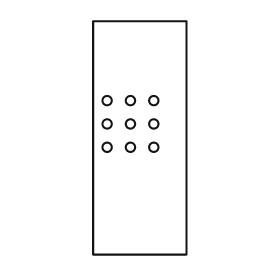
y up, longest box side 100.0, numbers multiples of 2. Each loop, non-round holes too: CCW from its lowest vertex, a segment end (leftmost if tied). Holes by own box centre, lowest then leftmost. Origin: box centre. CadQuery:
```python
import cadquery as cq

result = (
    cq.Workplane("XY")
    .moveTo(-20.0, -50.0)
    .lineTo(20.0, -50.0)
    .lineTo(20.0, 50.0)
    .lineTo(-20.0, 50.0)
    .close()
    .moveTo(-14.0, -4.0)
    .circle(2.0)
    .moveTo(-4.0, -4.0)
    .circle(2.0)
    .moveTo(6.0, -4.0)
    .circle(2.0)
    .moveTo(-14.0, 6.0)
    .circle(2.0)
    .moveTo(-4.0, 6.0)
    .circle(2.0)
    .moveTo(6.0, 6.0)
    .circle(2.0)
    .moveTo(-14.0, 16.0)
    .circle(2.0)
    .moveTo(-4.0, 16.0)
    .circle(2.0)
    .moveTo(6.0, 16.0)
    .circle(2.0)
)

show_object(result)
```